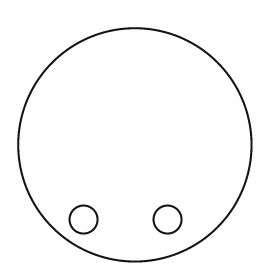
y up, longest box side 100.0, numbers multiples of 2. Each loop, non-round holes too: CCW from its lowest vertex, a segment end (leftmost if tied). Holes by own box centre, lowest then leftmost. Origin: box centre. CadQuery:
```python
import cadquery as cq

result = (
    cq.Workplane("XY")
    .moveTo(0.0, 0.0)
    .circle(50.0)
    .moveTo(-22.0, -32.0)
    .circle(6.0)
    .moveTo(14.0, -32.0)
    .circle(6.0)
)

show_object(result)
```